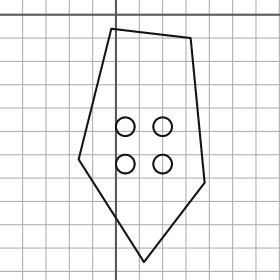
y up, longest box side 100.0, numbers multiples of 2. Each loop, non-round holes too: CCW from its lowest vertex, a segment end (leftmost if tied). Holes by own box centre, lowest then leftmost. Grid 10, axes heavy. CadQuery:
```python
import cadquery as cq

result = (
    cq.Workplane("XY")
    .moveTo(12.0, -106.0)
    .lineTo(38.0, -72.0)
    .lineTo(32.0, -10.0)
    .lineTo(-2.0, -6.0)
    .lineTo(-16.0, -62.0)
    .close()
    .moveTo(4.0, -64.0)
    .circle(4.0)
    .moveTo(20.0, -64.0)
    .circle(4.0)
    .moveTo(4.0, -48.0)
    .circle(4.0)
    .moveTo(20.0, -48.0)
    .circle(4.0)
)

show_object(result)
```